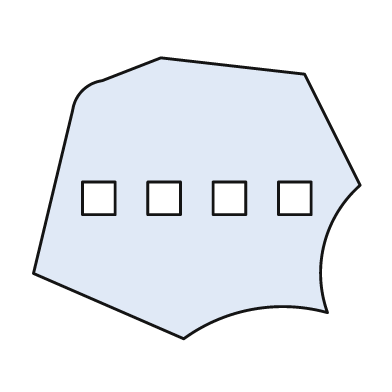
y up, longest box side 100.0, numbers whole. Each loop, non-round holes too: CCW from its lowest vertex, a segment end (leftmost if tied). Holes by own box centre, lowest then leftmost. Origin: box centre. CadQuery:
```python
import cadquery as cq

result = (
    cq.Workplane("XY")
    .moveTo(-4.0, -43.0)
    .threePointArc((17.0, -34.0), (40.0, -35.0))
    .threePointArc((39.0, -14.0), (50.0, 4.0))
    .lineTo(33.0, 38.0)
    .lineTo(-11.0, 43.0)
    .lineTo(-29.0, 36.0)
    .threePointArc((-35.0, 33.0), (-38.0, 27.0))
    .lineTo(-50.0, -23.0)
    .close()
    .moveTo(-35.0, -5.0)
    .lineTo(-25.0, -5.0)
    .lineTo(-25.0, 5.0)
    .lineTo(-35.0, 5.0)
    .close()
    .moveTo(-15.0, -5.0)
    .lineTo(-5.0, -5.0)
    .lineTo(-5.0, 5.0)
    .lineTo(-15.0, 5.0)
    .close()
    .moveTo(5.0, -5.0)
    .lineTo(15.0, -5.0)
    .lineTo(15.0, 5.0)
    .lineTo(5.0, 5.0)
    .close()
    .moveTo(25.0, -5.0)
    .lineTo(35.0, -5.0)
    .lineTo(35.0, 5.0)
    .lineTo(25.0, 5.0)
    .close()
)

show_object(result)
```